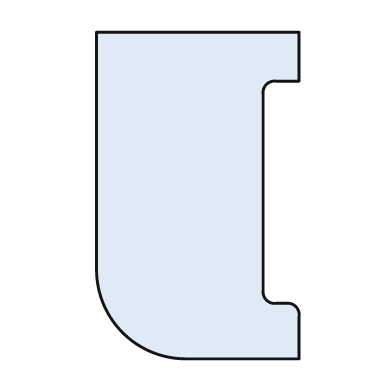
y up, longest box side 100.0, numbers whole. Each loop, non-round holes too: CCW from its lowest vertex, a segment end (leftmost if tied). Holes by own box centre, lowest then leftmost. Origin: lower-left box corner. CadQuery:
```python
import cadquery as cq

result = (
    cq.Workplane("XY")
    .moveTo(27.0, 0.0)
    .lineTo(62.0, 0.0)
    .lineTo(62.0, 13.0)
    .threePointArc((61.0, 16.0), (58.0, 17.0))
    .lineTo(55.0, 17.0)
    .threePointArc((52.0, 18.0), (51.0, 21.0))
    .lineTo(51.0, 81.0)
    .threePointArc((52.0, 84.0), (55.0, 85.0))
    .lineTo(62.0, 85.0)
    .lineTo(62.0, 100.0)
    .lineTo(0.0, 100.0)
    .lineTo(0.0, 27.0)
    .threePointArc((8.0, 8.0), (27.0, 0.0))
    .close()
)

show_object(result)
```